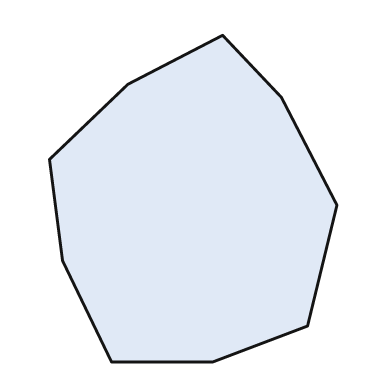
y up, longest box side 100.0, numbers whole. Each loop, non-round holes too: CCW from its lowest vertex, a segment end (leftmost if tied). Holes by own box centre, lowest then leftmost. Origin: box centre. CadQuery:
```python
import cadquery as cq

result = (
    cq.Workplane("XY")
    .moveTo(-25.0, -50.0)
    .lineTo(6.0, -50.0)
    .lineTo(35.0, -39.0)
    .lineTo(44.0, -2.0)
    .lineTo(27.0, 31.0)
    .lineTo(9.0, 50.0)
    .lineTo(-20.0, 35.0)
    .lineTo(-44.0, 12.0)
    .lineTo(-40.0, -19.0)
    .close()
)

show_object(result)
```